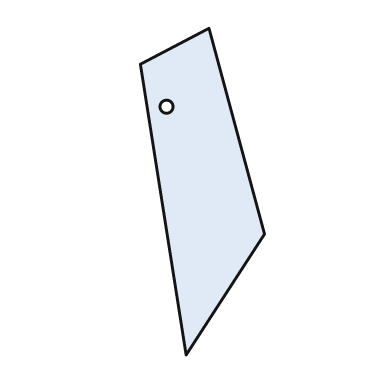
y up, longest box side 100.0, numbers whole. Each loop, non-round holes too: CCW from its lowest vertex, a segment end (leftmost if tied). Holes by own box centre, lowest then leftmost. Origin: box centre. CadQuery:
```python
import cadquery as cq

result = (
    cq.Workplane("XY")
    .moveTo(-5.0, -50.0)
    .lineTo(19.0, -13.0)
    .lineTo(2.0, 50.0)
    .lineTo(-19.0, 39.0)
    .close()
    .moveTo(-11.0, 26.0)
    .circle(2.0)
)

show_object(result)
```